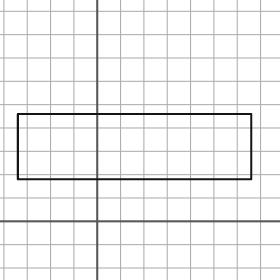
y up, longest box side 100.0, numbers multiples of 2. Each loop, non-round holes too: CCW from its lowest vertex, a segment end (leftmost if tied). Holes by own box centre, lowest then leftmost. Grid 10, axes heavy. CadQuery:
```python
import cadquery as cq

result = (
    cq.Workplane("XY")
    .moveTo(-34.0, 18.0)
    .lineTo(66.0, 18.0)
    .lineTo(66.0, 46.0)
    .lineTo(-34.0, 46.0)
    .close()
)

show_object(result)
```